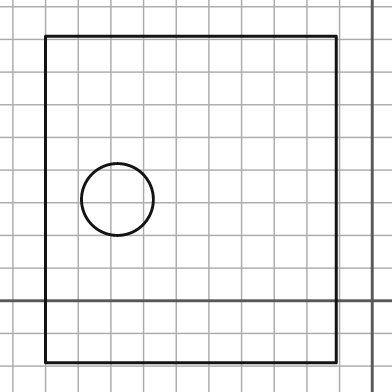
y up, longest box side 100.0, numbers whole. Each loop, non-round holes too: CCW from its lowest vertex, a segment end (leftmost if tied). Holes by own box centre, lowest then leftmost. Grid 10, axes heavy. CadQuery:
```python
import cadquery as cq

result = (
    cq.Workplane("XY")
    .moveTo(-100.0, -19.0)
    .lineTo(-11.0, -19.0)
    .lineTo(-11.0, 81.0)
    .lineTo(-100.0, 81.0)
    .close()
    .moveTo(-78.0, 31.0)
    .circle(11.0)
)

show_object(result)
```